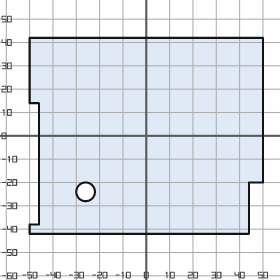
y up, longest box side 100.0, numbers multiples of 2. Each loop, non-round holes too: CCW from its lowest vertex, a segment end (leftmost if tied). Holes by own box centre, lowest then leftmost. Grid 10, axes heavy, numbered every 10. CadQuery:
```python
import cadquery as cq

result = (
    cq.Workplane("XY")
    .moveTo(-50.0, -42.0)
    .lineTo(44.0, -42.0)
    .lineTo(44.0, -20.0)
    .lineTo(50.0, -20.0)
    .lineTo(50.0, 42.0)
    .lineTo(-50.0, 42.0)
    .lineTo(-50.0, 14.0)
    .lineTo(-46.0, 14.0)
    .lineTo(-46.0, -38.0)
    .lineTo(-50.0, -38.0)
    .close()
    .moveTo(-26.0, -24.0)
    .circle(4.0)
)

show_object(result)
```